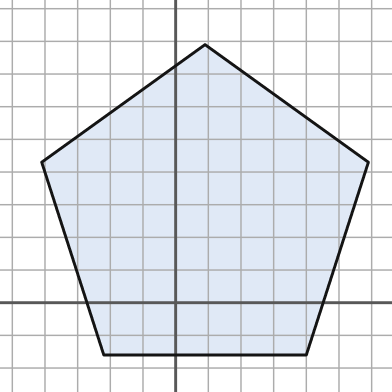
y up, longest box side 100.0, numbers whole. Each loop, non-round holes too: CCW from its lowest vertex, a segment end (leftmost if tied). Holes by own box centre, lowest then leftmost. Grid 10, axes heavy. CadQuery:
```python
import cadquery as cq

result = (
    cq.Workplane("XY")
    .moveTo(-22.0, -16.0)
    .lineTo(40.0, -16.0)
    .lineTo(59.0, 43.0)
    .lineTo(9.0, 79.0)
    .lineTo(-41.0, 43.0)
    .close()
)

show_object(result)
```